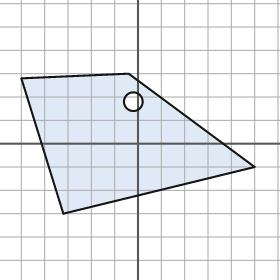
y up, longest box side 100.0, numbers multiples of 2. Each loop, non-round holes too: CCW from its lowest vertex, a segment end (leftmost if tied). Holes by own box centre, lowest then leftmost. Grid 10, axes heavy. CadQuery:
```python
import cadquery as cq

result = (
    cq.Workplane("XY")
    .moveTo(-32.0, -30.0)
    .lineTo(50.0, -10.0)
    .lineTo(-4.0, 30.0)
    .lineTo(-50.0, 28.0)
    .close()
    .moveTo(-2.0, 18.0)
    .circle(4.0)
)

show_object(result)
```